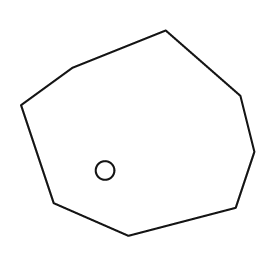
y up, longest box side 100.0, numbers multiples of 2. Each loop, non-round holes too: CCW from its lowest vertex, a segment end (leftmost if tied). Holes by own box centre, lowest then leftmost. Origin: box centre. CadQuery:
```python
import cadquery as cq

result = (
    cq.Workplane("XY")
    .moveTo(-4.0, -44.0)
    .lineTo(42.0, -32.0)
    .lineTo(50.0, -8.0)
    .lineTo(44.0, 16.0)
    .lineTo(12.0, 44.0)
    .lineTo(-28.0, 28.0)
    .lineTo(-50.0, 12.0)
    .lineTo(-36.0, -30.0)
    .close()
    .moveTo(-14.0, -16.0)
    .circle(4.0)
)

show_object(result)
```